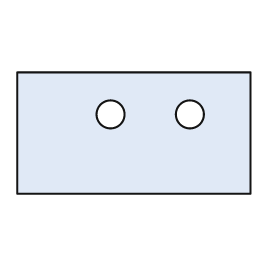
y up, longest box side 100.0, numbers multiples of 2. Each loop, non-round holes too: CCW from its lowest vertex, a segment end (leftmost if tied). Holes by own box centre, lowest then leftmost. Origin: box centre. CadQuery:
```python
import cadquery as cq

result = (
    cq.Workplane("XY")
    .moveTo(-50.0, -26.0)
    .lineTo(50.0, -26.0)
    .lineTo(50.0, 26.0)
    .lineTo(-50.0, 26.0)
    .close()
    .moveTo(-10.0, 8.0)
    .circle(6.0)
    .moveTo(24.0, 8.0)
    .circle(6.0)
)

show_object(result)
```